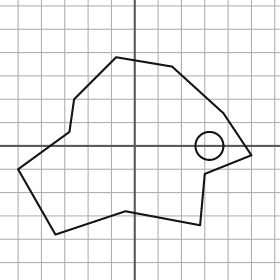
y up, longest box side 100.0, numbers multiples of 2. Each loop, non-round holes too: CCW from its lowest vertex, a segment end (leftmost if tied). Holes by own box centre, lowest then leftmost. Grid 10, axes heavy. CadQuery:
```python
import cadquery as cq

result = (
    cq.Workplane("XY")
    .moveTo(-34.0, -38.0)
    .lineTo(-4.0, -28.0)
    .lineTo(28.0, -34.0)
    .lineTo(30.0, -12.0)
    .lineTo(50.0, -4.0)
    .lineTo(38.0, 14.0)
    .lineTo(16.0, 34.0)
    .lineTo(-8.0, 38.0)
    .lineTo(-26.0, 20.0)
    .lineTo(-28.0, 6.0)
    .lineTo(-50.0, -10.0)
    .close()
    .moveTo(32.0, 0.0)
    .circle(6.0)
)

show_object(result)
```